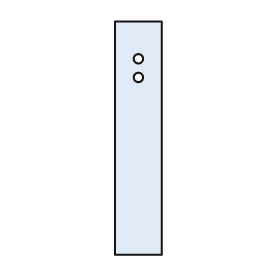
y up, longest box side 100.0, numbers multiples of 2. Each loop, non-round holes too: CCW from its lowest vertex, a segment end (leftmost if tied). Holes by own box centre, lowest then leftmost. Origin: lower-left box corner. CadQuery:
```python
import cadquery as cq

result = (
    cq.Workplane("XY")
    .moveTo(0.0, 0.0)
    .lineTo(20.0, 0.0)
    .lineTo(20.0, 100.0)
    .lineTo(0.0, 100.0)
    .close()
    .moveTo(10.0, 76.0)
    .circle(2.0)
    .moveTo(10.0, 84.0)
    .circle(2.0)
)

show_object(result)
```